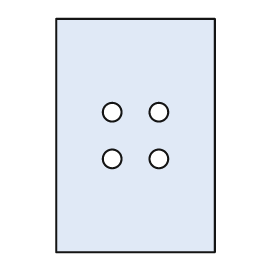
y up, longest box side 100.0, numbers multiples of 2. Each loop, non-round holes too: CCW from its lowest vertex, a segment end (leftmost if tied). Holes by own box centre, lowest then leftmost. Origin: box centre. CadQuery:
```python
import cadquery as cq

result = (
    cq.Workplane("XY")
    .moveTo(-34.0, -50.0)
    .lineTo(34.0, -50.0)
    .lineTo(34.0, 50.0)
    .lineTo(-34.0, 50.0)
    .close()
    .moveTo(-10.0, -10.0)
    .circle(4.0)
    .moveTo(10.0, -10.0)
    .circle(4.0)
    .moveTo(-10.0, 10.0)
    .circle(4.0)
    .moveTo(10.0, 10.0)
    .circle(4.0)
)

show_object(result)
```